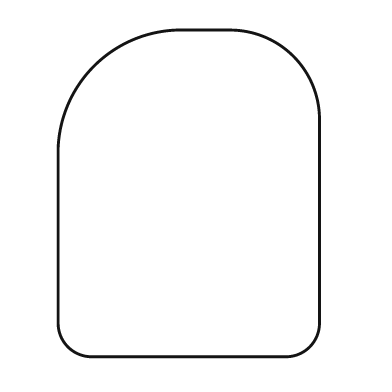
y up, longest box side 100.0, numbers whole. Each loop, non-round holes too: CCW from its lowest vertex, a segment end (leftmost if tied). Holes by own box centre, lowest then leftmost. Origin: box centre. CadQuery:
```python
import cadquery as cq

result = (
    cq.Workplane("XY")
    .moveTo(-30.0, -50.0)
    .lineTo(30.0, -50.0)
    .threePointArc((37.0, -47.0), (40.0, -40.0))
    .lineTo(40.0, 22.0)
    .threePointArc((32.0, 42.0), (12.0, 50.0))
    .lineTo(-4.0, 50.0)
    .threePointArc((-29.0, 39.0), (-40.0, 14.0))
    .lineTo(-40.0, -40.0)
    .threePointArc((-37.0, -47.0), (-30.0, -50.0))
    .close()
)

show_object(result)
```